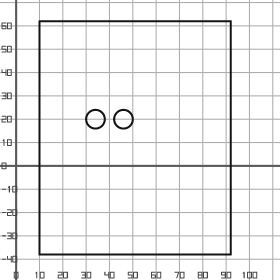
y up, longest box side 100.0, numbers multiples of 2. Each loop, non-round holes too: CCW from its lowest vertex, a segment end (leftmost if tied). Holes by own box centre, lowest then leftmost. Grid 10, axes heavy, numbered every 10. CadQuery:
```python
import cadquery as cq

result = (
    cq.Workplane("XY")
    .moveTo(10.0, -38.0)
    .lineTo(92.0, -38.0)
    .lineTo(92.0, 62.0)
    .lineTo(10.0, 62.0)
    .close()
    .moveTo(34.0, 20.0)
    .circle(4.0)
    .moveTo(46.0, 20.0)
    .circle(4.0)
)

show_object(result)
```